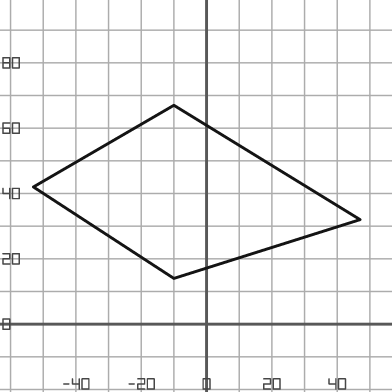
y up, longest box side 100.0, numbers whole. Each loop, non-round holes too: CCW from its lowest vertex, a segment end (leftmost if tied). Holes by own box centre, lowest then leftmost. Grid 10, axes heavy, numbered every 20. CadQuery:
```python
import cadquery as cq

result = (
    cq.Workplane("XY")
    .moveTo(-10.0, 14.0)
    .lineTo(47.0, 32.0)
    .lineTo(-10.0, 67.0)
    .lineTo(-53.0, 42.0)
    .close()
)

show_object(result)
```